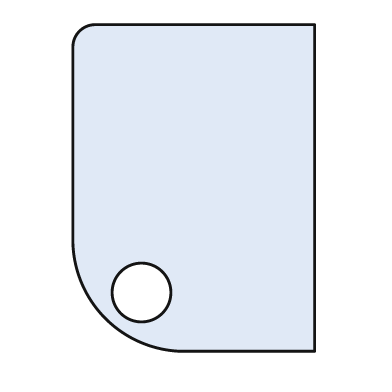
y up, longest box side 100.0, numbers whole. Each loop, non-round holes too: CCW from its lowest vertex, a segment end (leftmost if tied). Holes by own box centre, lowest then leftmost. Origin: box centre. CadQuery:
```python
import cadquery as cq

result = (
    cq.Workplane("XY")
    .moveTo(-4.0, -50.0)
    .lineTo(37.0, -50.0)
    .lineTo(37.0, 50.0)
    .lineTo(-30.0, 50.0)
    .threePointArc((-35.0, 48.0), (-37.0, 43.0))
    .lineTo(-37.0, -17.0)
    .threePointArc((-27.0, -40.0), (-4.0, -50.0))
    .close()
    .moveTo(-16.0, -32.0)
    .circle(9.0)
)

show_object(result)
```